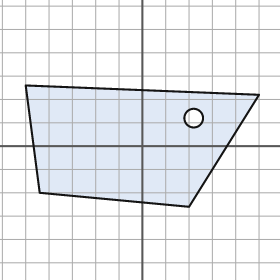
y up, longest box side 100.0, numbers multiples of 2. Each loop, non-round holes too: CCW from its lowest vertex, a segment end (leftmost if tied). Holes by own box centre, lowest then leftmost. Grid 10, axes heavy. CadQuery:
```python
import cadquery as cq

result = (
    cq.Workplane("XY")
    .moveTo(20.0, -26.0)
    .lineTo(50.0, 22.0)
    .lineTo(-50.0, 26.0)
    .lineTo(-44.0, -20.0)
    .close()
    .moveTo(22.0, 12.0)
    .circle(4.0)
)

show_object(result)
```